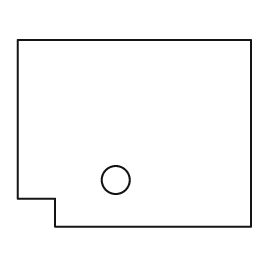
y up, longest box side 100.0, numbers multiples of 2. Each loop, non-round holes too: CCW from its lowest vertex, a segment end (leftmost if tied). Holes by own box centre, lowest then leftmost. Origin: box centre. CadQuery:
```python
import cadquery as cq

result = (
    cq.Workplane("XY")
    .moveTo(-34.0, -40.0)
    .lineTo(50.0, -40.0)
    .lineTo(50.0, 40.0)
    .lineTo(-50.0, 40.0)
    .lineTo(-50.0, -28.0)
    .lineTo(-34.0, -28.0)
    .close()
    .moveTo(-8.0, -20.0)
    .circle(6.0)
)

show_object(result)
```